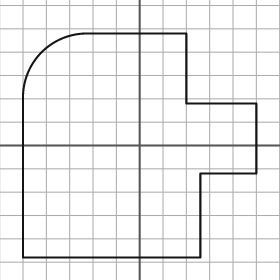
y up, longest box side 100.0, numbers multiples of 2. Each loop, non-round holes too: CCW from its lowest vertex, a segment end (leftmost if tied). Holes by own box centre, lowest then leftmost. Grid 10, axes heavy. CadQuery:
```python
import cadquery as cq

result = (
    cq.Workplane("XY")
    .moveTo(-50.0, -48.0)
    .lineTo(26.0, -48.0)
    .lineTo(26.0, -12.0)
    .lineTo(50.0, -12.0)
    .lineTo(50.0, 18.0)
    .lineTo(20.0, 18.0)
    .lineTo(20.0, 48.0)
    .lineTo(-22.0, 48.0)
    .threePointArc((-42.0, 40.0), (-50.0, 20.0))
    .close()
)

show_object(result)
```